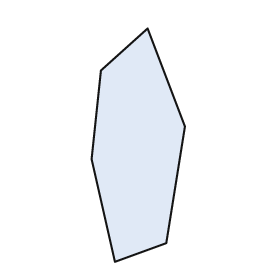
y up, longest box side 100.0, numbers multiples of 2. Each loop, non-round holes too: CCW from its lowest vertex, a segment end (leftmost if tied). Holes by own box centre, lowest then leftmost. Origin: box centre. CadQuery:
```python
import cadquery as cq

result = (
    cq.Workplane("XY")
    .moveTo(-10.0, -50.0)
    .lineTo(12.0, -42.0)
    .lineTo(20.0, 8.0)
    .lineTo(4.0, 50.0)
    .lineTo(-16.0, 32.0)
    .lineTo(-20.0, -6.0)
    .close()
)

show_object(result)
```